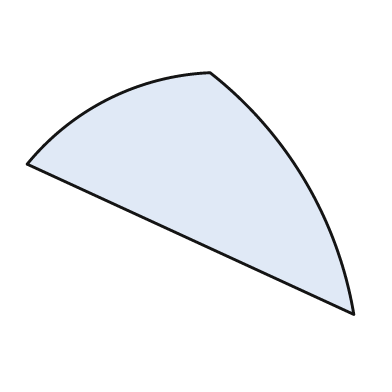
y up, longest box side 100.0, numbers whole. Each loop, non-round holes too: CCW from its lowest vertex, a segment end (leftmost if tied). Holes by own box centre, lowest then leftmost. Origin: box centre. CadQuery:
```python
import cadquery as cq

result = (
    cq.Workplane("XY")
    .moveTo(50.0, -37.0)
    .threePointArc((35.0, 4.0), (6.0, 37.0))
    .threePointArc((-25.0, 29.0), (-50.0, 9.0))
    .close()
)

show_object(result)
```